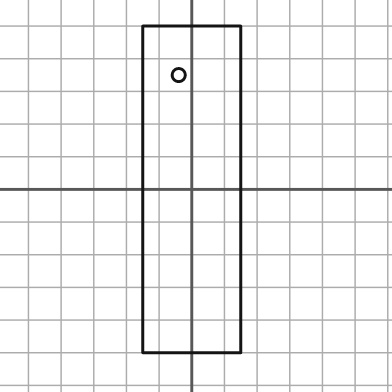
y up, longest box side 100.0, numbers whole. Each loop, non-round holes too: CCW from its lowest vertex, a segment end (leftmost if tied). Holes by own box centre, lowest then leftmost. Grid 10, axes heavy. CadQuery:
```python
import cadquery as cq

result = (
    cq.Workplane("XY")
    .moveTo(-15.0, -50.0)
    .lineTo(15.0, -50.0)
    .lineTo(15.0, 50.0)
    .lineTo(-15.0, 50.0)
    .close()
    .moveTo(-4.0, 35.0)
    .circle(2.0)
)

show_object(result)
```